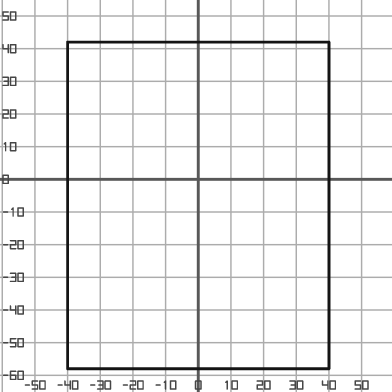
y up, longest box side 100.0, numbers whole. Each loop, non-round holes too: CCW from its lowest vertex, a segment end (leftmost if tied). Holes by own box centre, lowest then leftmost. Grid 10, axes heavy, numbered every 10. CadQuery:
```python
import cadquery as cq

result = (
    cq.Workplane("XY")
    .moveTo(-40.0, -58.0)
    .lineTo(40.0, -58.0)
    .lineTo(40.0, 42.0)
    .lineTo(-40.0, 42.0)
    .close()
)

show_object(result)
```